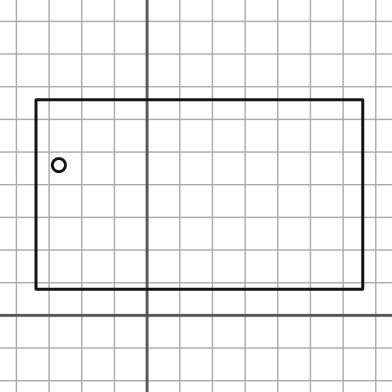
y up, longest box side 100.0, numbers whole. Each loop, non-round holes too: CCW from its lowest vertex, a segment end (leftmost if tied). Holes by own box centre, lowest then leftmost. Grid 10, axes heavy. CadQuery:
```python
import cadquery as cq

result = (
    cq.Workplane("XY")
    .moveTo(-34.0, 8.0)
    .lineTo(66.0, 8.0)
    .lineTo(66.0, 66.0)
    .lineTo(-34.0, 66.0)
    .close()
    .moveTo(-27.0, 46.0)
    .circle(2.0)
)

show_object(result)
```